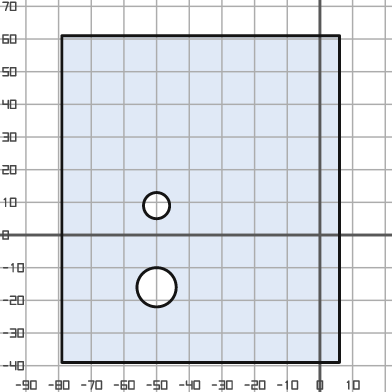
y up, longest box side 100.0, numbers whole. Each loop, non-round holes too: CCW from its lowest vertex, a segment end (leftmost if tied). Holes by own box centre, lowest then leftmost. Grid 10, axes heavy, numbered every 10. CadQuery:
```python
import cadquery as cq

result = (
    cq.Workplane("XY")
    .moveTo(-79.0, -39.0)
    .lineTo(6.0, -39.0)
    .lineTo(6.0, 61.0)
    .lineTo(-79.0, 61.0)
    .close()
    .moveTo(-50.0, -16.0)
    .circle(6.0)
    .moveTo(-50.0, 9.0)
    .circle(4.0)
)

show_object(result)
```